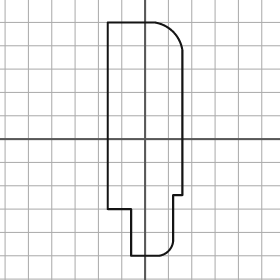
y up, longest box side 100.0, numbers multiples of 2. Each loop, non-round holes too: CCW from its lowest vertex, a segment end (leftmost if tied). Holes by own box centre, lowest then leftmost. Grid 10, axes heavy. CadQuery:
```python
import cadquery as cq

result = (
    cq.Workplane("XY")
    .moveTo(-6.0, -50.0)
    .lineTo(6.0, -50.0)
    .threePointArc((10.0, -48.0), (12.0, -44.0))
    .lineTo(12.0, -24.0)
    .lineTo(16.0, -24.0)
    .lineTo(16.0, 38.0)
    .threePointArc((12.0, 46.0), (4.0, 50.0))
    .lineTo(-16.0, 50.0)
    .lineTo(-16.0, -30.0)
    .lineTo(-6.0, -30.0)
    .close()
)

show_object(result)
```